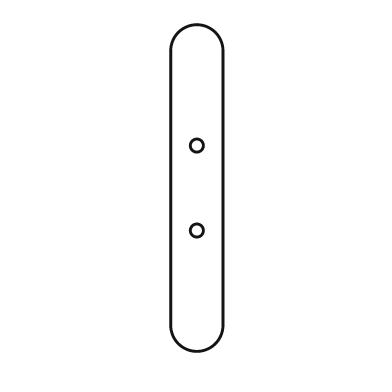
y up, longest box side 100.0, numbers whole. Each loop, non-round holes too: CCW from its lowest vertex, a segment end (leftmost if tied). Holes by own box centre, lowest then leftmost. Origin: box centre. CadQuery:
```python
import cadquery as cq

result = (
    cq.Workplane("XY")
    .moveTo(-8.0, -42.0)
    .threePointArc((0.0, -50.0), (8.0, -42.0))
    .lineTo(8.0, 42.0)
    .threePointArc((0.0, 50.0), (-8.0, 42.0))
    .close()
    .moveTo(0.0, -13.0)
    .circle(2.0)
    .moveTo(0.0, 13.0)
    .circle(2.0)
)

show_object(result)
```